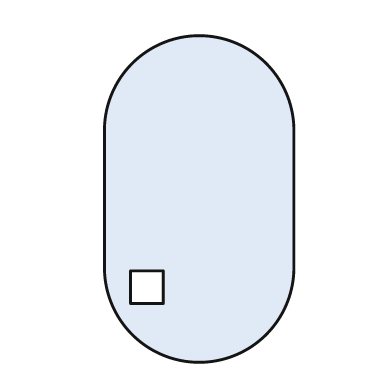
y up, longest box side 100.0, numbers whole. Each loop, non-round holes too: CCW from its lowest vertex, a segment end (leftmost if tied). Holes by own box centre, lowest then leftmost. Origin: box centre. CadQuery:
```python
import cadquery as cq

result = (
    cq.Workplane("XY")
    .moveTo(-29.0, -21.0)
    .threePointArc((0.0, -50.0), (29.0, -21.0))
    .lineTo(29.0, 21.0)
    .threePointArc((0.0, 50.0), (-29.0, 21.0))
    .close()
    .moveTo(-21.0, -32.0)
    .lineTo(-11.0, -32.0)
    .lineTo(-11.0, -22.0)
    .lineTo(-21.0, -22.0)
    .close()
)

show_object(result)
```